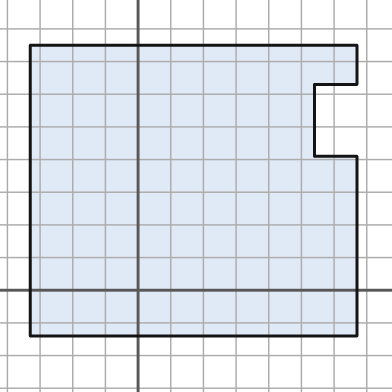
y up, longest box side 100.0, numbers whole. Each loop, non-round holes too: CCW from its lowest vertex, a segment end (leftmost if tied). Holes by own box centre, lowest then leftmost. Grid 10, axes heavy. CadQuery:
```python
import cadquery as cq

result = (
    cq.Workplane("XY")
    .moveTo(-33.0, -14.0)
    .lineTo(67.0, -14.0)
    .lineTo(67.0, 41.0)
    .lineTo(54.0, 41.0)
    .lineTo(54.0, 63.0)
    .lineTo(67.0, 63.0)
    .lineTo(67.0, 75.0)
    .lineTo(-33.0, 75.0)
    .close()
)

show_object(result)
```